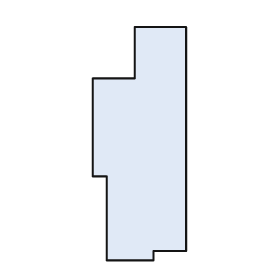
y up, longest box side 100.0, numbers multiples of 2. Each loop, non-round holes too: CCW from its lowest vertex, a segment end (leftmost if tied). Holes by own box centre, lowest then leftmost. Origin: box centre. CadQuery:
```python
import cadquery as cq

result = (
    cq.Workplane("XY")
    .moveTo(-14.0, -50.0)
    .lineTo(6.0, -50.0)
    .lineTo(6.0, -46.0)
    .lineTo(20.0, -46.0)
    .lineTo(20.0, 50.0)
    .lineTo(-2.0, 50.0)
    .lineTo(-2.0, 28.0)
    .lineTo(-20.0, 28.0)
    .lineTo(-20.0, -14.0)
    .lineTo(-14.0, -14.0)
    .close()
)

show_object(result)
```